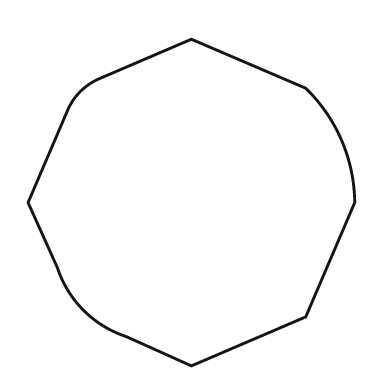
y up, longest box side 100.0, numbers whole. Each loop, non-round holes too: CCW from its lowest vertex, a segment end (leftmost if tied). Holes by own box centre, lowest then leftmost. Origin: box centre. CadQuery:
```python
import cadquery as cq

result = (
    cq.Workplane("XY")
    .moveTo(0.0, -50.0)
    .lineTo(35.0, -35.0)
    .lineTo(50.0, 0.0)
    .threePointArc((46.0, 19.0), (35.0, 35.0))
    .lineTo(0.0, 50.0)
    .lineTo(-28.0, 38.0)
    .threePointArc((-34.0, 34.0), (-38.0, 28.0))
    .lineTo(-50.0, 0.0)
    .lineTo(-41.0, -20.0)
    .threePointArc((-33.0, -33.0), (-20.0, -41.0))
    .close()
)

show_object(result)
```